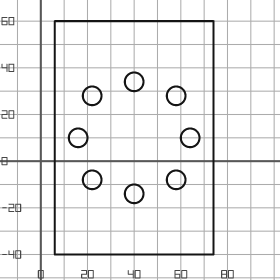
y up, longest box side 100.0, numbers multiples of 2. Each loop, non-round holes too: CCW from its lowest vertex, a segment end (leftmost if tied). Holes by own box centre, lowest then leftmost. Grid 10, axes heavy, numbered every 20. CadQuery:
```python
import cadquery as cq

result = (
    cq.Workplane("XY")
    .moveTo(6.0, -40.0)
    .lineTo(74.0, -40.0)
    .lineTo(74.0, 60.0)
    .lineTo(6.0, 60.0)
    .close()
    .moveTo(40.0, -14.0)
    .circle(4.0)
    .moveTo(22.0, -8.0)
    .circle(4.0)
    .moveTo(58.0, -8.0)
    .circle(4.0)
    .moveTo(16.0, 10.0)
    .circle(4.0)
    .moveTo(64.0, 10.0)
    .circle(4.0)
    .moveTo(22.0, 28.0)
    .circle(4.0)
    .moveTo(58.0, 28.0)
    .circle(4.0)
    .moveTo(40.0, 34.0)
    .circle(4.0)
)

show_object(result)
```